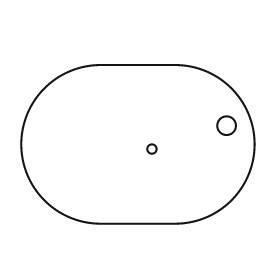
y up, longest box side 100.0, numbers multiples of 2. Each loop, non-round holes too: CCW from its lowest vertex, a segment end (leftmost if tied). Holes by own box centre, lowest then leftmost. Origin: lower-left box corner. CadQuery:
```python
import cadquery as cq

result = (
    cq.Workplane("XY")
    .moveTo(34.0, 0.0)
    .lineTo(66.0, 0.0)
    .threePointArc((100.0, 34.0), (66.0, 68.0))
    .lineTo(34.0, 68.0)
    .threePointArc((0.0, 34.0), (34.0, 0.0))
    .close()
    .moveTo(56.0, 32.0)
    .circle(2.0)
    .moveTo(88.0, 42.0)
    .circle(4.0)
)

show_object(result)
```